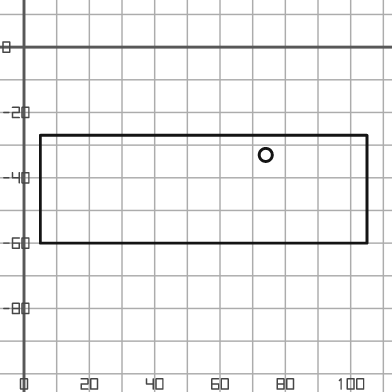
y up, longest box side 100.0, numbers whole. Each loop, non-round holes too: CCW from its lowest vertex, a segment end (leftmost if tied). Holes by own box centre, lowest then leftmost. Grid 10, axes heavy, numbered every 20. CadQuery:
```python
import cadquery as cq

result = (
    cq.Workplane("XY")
    .moveTo(5.0, -60.0)
    .lineTo(105.0, -60.0)
    .lineTo(105.0, -27.0)
    .lineTo(5.0, -27.0)
    .close()
    .moveTo(74.0, -33.0)
    .circle(2.0)
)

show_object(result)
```